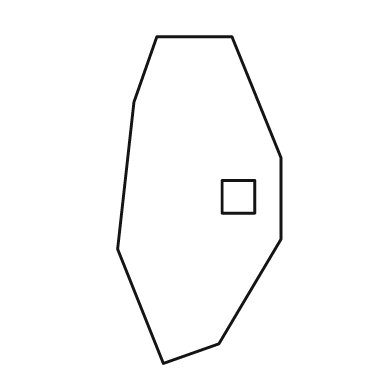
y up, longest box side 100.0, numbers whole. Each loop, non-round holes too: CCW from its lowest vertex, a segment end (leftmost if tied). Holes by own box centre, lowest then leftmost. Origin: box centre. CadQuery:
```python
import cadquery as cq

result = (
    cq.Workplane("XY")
    .moveTo(-11.0, -50.0)
    .lineTo(6.0, -44.0)
    .lineTo(25.0, -12.0)
    .lineTo(25.0, 13.0)
    .lineTo(10.0, 50.0)
    .lineTo(-13.0, 50.0)
    .lineTo(-20.0, 30.0)
    .lineTo(-25.0, -15.0)
    .close()
    .moveTo(7.0, -4.0)
    .lineTo(17.0, -4.0)
    .lineTo(17.0, 6.0)
    .lineTo(7.0, 6.0)
    .close()
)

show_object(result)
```